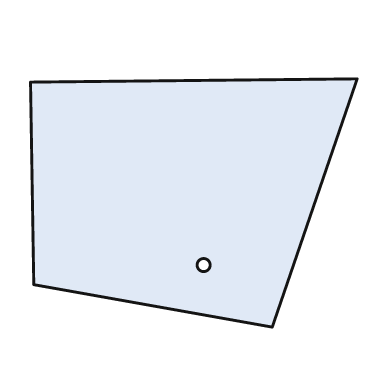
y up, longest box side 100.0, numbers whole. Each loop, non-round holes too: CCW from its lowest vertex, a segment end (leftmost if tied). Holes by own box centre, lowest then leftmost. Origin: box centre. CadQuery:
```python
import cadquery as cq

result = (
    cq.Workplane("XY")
    .moveTo(24.0, -38.0)
    .lineTo(50.0, 38.0)
    .lineTo(-50.0, 37.0)
    .lineTo(-49.0, -25.0)
    .close()
    .moveTo(3.0, -19.0)
    .circle(2.0)
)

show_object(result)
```